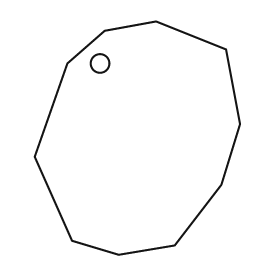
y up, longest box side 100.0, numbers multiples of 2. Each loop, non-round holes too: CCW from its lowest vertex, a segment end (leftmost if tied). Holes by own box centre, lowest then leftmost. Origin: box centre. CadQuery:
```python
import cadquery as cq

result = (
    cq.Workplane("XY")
    .moveTo(-8.0, -50.0)
    .lineTo(16.0, -46.0)
    .lineTo(36.0, -20.0)
    .lineTo(44.0, 6.0)
    .lineTo(38.0, 38.0)
    .lineTo(8.0, 50.0)
    .lineTo(-14.0, 46.0)
    .lineTo(-30.0, 32.0)
    .lineTo(-44.0, -8.0)
    .lineTo(-28.0, -44.0)
    .close()
    .moveTo(-16.0, 32.0)
    .circle(4.0)
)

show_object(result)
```